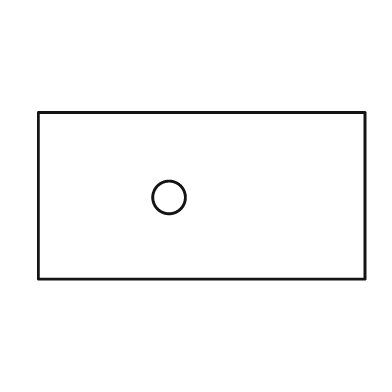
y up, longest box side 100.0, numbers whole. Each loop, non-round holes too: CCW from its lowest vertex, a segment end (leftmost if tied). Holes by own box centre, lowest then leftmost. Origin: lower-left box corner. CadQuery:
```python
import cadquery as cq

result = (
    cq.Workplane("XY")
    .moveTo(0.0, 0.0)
    .lineTo(100.0, 0.0)
    .lineTo(100.0, 51.0)
    .lineTo(0.0, 51.0)
    .close()
    .moveTo(40.0, 25.0)
    .circle(5.0)
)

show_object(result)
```